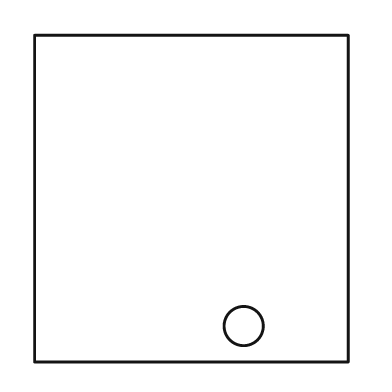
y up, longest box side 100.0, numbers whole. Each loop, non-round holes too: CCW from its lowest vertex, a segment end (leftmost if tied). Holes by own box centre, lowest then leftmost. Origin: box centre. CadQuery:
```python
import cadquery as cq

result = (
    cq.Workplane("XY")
    .moveTo(-48.0, -50.0)
    .lineTo(48.0, -50.0)
    .lineTo(48.0, 50.0)
    .lineTo(-48.0, 50.0)
    .close()
    .moveTo(16.0, -39.0)
    .circle(6.0)
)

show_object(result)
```